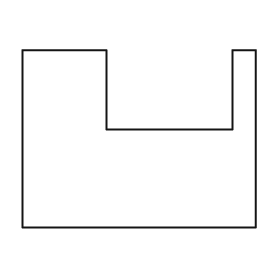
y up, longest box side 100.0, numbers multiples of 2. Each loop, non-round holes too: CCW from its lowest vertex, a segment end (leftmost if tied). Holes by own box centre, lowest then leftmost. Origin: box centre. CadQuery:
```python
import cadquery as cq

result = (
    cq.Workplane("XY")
    .moveTo(-50.0, -38.0)
    .lineTo(50.0, -38.0)
    .lineTo(50.0, 38.0)
    .lineTo(40.0, 38.0)
    .lineTo(40.0, 4.0)
    .lineTo(-14.0, 4.0)
    .lineTo(-14.0, 38.0)
    .lineTo(-50.0, 38.0)
    .close()
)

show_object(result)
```